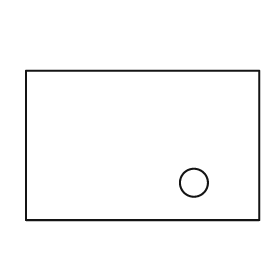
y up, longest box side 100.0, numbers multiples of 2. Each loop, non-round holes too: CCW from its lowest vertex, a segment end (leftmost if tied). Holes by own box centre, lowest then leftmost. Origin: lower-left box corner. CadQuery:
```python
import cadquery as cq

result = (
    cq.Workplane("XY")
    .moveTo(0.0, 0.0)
    .lineTo(100.0, 0.0)
    .lineTo(100.0, 64.0)
    .lineTo(0.0, 64.0)
    .close()
    .moveTo(72.0, 16.0)
    .circle(6.0)
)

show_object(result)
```